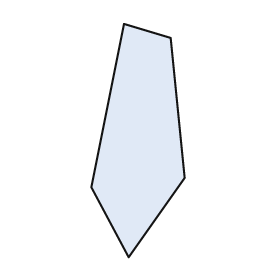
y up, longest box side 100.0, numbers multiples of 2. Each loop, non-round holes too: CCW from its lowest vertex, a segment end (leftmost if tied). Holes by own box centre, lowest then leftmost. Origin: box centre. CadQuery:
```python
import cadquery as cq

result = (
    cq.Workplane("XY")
    .moveTo(-4.0, -50.0)
    .lineTo(20.0, -16.0)
    .lineTo(14.0, 44.0)
    .lineTo(-6.0, 50.0)
    .lineTo(-20.0, -20.0)
    .close()
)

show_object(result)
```